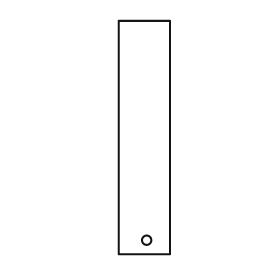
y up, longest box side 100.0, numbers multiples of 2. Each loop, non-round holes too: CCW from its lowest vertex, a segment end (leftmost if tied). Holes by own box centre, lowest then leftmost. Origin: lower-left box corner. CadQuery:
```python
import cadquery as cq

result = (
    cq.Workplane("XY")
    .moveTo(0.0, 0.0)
    .lineTo(22.0, 0.0)
    .lineTo(22.0, 100.0)
    .lineTo(0.0, 100.0)
    .close()
    .moveTo(12.0, 6.0)
    .circle(2.0)
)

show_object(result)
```